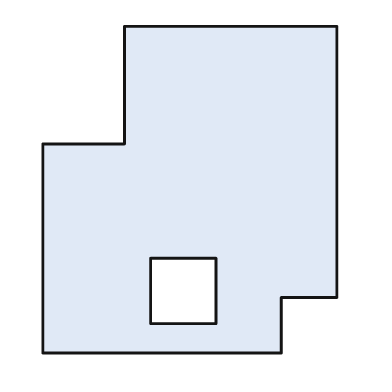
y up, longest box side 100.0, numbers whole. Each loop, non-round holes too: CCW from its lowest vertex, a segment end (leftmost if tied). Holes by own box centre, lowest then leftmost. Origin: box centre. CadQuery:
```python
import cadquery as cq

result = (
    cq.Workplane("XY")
    .moveTo(-45.0, -50.0)
    .lineTo(28.0, -50.0)
    .lineTo(28.0, -33.0)
    .lineTo(45.0, -33.0)
    .lineTo(45.0, 50.0)
    .lineTo(-20.0, 50.0)
    .lineTo(-20.0, 14.0)
    .lineTo(-45.0, 14.0)
    .close()
    .moveTo(-12.0, -41.0)
    .lineTo(8.0, -41.0)
    .lineTo(8.0, -21.0)
    .lineTo(-12.0, -21.0)
    .close()
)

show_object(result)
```